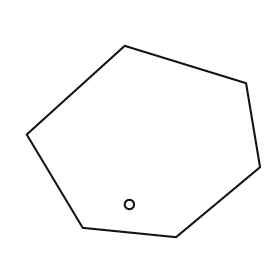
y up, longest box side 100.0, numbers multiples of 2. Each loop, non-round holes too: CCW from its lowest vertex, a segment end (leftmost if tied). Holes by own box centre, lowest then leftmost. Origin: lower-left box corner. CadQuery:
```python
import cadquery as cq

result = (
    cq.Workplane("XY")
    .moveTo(64.0, 0.0)
    .lineTo(100.0, 30.0)
    .lineTo(94.0, 66.0)
    .lineTo(42.0, 82.0)
    .lineTo(0.0, 44.0)
    .lineTo(24.0, 4.0)
    .close()
    .moveTo(44.0, 14.0)
    .circle(2.0)
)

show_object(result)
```